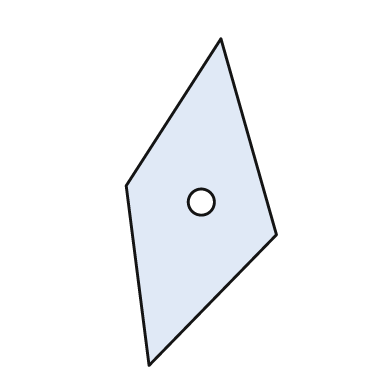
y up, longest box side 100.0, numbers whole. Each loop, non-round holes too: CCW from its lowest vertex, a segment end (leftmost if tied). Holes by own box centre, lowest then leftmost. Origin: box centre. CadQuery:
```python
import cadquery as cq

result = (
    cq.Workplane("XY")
    .moveTo(-16.0, -50.0)
    .lineTo(23.0, -10.0)
    .lineTo(6.0, 50.0)
    .lineTo(-23.0, 5.0)
    .close()
    .moveTo(0.0, 0.0)
    .circle(4.0)
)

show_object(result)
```